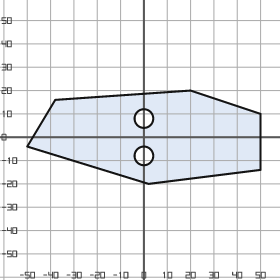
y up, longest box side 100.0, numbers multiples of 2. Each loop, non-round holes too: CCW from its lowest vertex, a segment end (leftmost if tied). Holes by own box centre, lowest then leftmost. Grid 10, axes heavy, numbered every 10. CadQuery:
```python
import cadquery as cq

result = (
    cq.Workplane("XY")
    .moveTo(2.0, -20.0)
    .lineTo(50.0, -14.0)
    .lineTo(50.0, 10.0)
    .lineTo(20.0, 20.0)
    .lineTo(-38.0, 16.0)
    .lineTo(-50.0, -4.0)
    .close()
    .moveTo(0.0, -8.0)
    .circle(4.0)
    .moveTo(0.0, 8.0)
    .circle(4.0)
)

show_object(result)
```